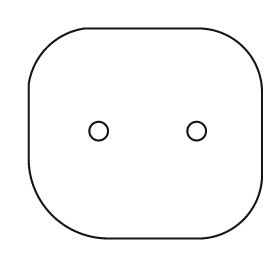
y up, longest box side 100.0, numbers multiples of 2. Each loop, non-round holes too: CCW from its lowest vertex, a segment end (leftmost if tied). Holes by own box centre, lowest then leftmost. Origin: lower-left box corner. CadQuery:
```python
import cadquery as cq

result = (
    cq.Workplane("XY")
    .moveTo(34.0, 0.0)
    .lineTo(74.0, 0.0)
    .threePointArc((92.0, 8.0), (100.0, 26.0))
    .lineTo(100.0, 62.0)
    .threePointArc((92.0, 82.0), (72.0, 90.0))
    .lineTo(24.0, 90.0)
    .threePointArc((8.0, 82.0), (0.0, 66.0))
    .lineTo(0.0, 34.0)
    .threePointArc((10.0, 10.0), (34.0, 0.0))
    .close()
    .moveTo(30.0, 46.0)
    .circle(4.0)
    .moveTo(72.0, 46.0)
    .circle(4.0)
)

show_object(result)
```